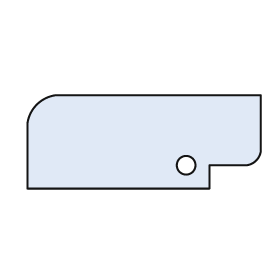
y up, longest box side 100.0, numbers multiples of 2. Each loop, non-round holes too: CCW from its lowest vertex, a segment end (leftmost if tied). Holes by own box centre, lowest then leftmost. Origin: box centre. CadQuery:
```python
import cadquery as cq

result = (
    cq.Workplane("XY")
    .moveTo(-50.0, -20.0)
    .lineTo(28.0, -20.0)
    .lineTo(28.0, -10.0)
    .lineTo(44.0, -10.0)
    .threePointArc((48.0, -8.0), (50.0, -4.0))
    .lineTo(50.0, 20.0)
    .lineTo(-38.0, 20.0)
    .threePointArc((-46.0, 16.0), (-50.0, 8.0))
    .close()
    .moveTo(18.0, -10.0)
    .circle(4.0)
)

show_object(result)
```